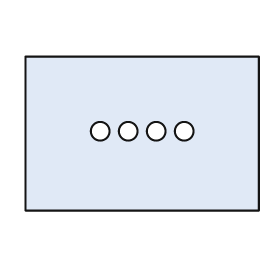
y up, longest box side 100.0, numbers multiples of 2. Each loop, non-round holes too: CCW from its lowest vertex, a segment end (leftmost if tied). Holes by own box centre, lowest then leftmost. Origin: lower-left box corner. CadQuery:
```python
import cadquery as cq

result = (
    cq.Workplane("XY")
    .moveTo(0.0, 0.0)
    .lineTo(100.0, 0.0)
    .lineTo(100.0, 66.0)
    .lineTo(0.0, 66.0)
    .close()
    .moveTo(32.0, 34.0)
    .circle(4.0)
    .moveTo(44.0, 34.0)
    .circle(4.0)
    .moveTo(56.0, 34.0)
    .circle(4.0)
    .moveTo(68.0, 34.0)
    .circle(4.0)
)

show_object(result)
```